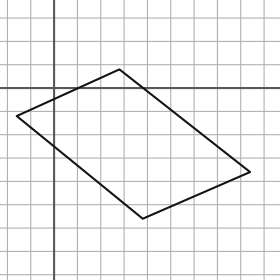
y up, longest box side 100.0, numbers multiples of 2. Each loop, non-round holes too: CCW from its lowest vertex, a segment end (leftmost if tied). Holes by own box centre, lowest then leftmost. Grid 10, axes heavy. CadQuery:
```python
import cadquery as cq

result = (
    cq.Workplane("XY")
    .moveTo(38.0, -56.0)
    .lineTo(84.0, -36.0)
    .lineTo(28.0, 8.0)
    .lineTo(-16.0, -12.0)
    .close()
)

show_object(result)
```